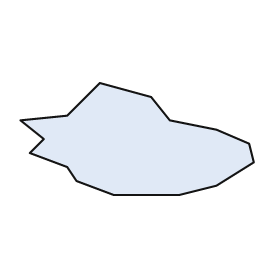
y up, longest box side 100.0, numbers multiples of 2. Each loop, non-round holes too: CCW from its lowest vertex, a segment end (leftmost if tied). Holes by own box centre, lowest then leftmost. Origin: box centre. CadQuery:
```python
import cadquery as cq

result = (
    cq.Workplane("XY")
    .moveTo(-10.0, -24.0)
    .lineTo(18.0, -24.0)
    .lineTo(34.0, -20.0)
    .lineTo(50.0, -10.0)
    .lineTo(48.0, -2.0)
    .lineTo(34.0, 4.0)
    .lineTo(14.0, 8.0)
    .lineTo(6.0, 18.0)
    .lineTo(-16.0, 24.0)
    .lineTo(-30.0, 10.0)
    .lineTo(-50.0, 8.0)
    .lineTo(-40.0, 0.0)
    .lineTo(-46.0, -6.0)
    .lineTo(-30.0, -12.0)
    .lineTo(-26.0, -18.0)
    .close()
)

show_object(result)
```